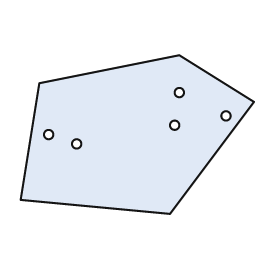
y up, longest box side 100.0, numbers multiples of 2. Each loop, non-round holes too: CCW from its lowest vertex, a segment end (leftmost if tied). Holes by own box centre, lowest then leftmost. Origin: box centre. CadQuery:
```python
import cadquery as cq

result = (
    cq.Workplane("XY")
    .moveTo(14.0, -34.0)
    .lineTo(50.0, 14.0)
    .lineTo(18.0, 34.0)
    .lineTo(-42.0, 22.0)
    .lineTo(-50.0, -28.0)
    .close()
    .moveTo(-26.0, -4.0)
    .circle(2.0)
    .moveTo(-38.0, 0.0)
    .circle(2.0)
    .moveTo(16.0, 4.0)
    .circle(2.0)
    .moveTo(38.0, 8.0)
    .circle(2.0)
    .moveTo(18.0, 18.0)
    .circle(2.0)
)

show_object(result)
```